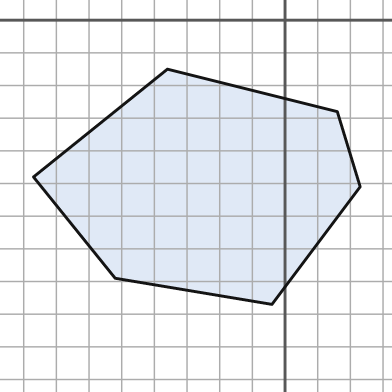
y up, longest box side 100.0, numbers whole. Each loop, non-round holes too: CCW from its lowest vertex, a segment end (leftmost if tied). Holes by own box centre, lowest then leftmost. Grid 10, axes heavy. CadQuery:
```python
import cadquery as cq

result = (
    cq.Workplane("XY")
    .moveTo(-4.0, -87.0)
    .lineTo(23.0, -51.0)
    .lineTo(16.0, -28.0)
    .lineTo(-36.0, -15.0)
    .lineTo(-77.0, -48.0)
    .lineTo(-52.0, -79.0)
    .close()
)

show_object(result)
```